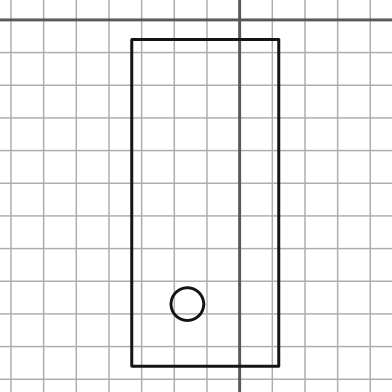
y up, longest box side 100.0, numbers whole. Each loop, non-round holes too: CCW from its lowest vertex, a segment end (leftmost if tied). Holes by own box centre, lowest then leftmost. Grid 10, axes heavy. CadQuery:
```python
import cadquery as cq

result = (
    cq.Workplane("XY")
    .moveTo(-33.0, -106.0)
    .lineTo(12.0, -106.0)
    .lineTo(12.0, -6.0)
    .lineTo(-33.0, -6.0)
    .close()
    .moveTo(-16.0, -87.0)
    .circle(5.0)
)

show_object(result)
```